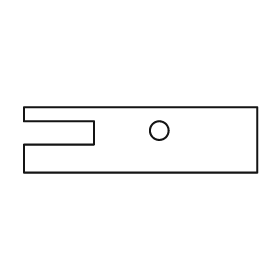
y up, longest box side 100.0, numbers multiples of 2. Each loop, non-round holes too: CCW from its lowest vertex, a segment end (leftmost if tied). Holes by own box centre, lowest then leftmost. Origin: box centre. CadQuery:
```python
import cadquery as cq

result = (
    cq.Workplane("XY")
    .moveTo(-50.0, -14.0)
    .lineTo(50.0, -14.0)
    .lineTo(50.0, 14.0)
    .lineTo(-50.0, 14.0)
    .lineTo(-50.0, 8.0)
    .lineTo(-20.0, 8.0)
    .lineTo(-20.0, -2.0)
    .lineTo(-50.0, -2.0)
    .close()
    .moveTo(8.0, 4.0)
    .circle(4.0)
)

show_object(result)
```